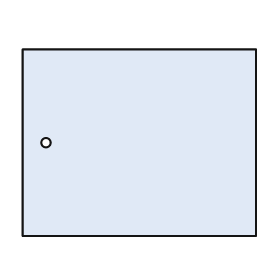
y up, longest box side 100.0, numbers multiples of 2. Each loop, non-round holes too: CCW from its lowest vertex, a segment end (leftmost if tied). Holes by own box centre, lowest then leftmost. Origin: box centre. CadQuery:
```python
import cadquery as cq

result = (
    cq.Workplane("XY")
    .moveTo(-50.0, -40.0)
    .lineTo(50.0, -40.0)
    .lineTo(50.0, 40.0)
    .lineTo(-50.0, 40.0)
    .close()
    .moveTo(-40.0, 0.0)
    .circle(2.0)
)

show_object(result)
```